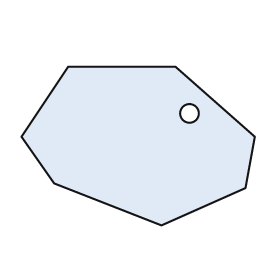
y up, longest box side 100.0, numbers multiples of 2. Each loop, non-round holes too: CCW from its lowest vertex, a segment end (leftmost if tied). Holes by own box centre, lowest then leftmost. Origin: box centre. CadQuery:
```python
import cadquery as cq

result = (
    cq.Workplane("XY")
    .moveTo(10.0, -34.0)
    .lineTo(46.0, -18.0)
    .lineTo(50.0, 4.0)
    .lineTo(16.0, 34.0)
    .lineTo(-30.0, 34.0)
    .lineTo(-50.0, 4.0)
    .lineTo(-36.0, -16.0)
    .close()
    .moveTo(22.0, 14.0)
    .circle(4.0)
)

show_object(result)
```